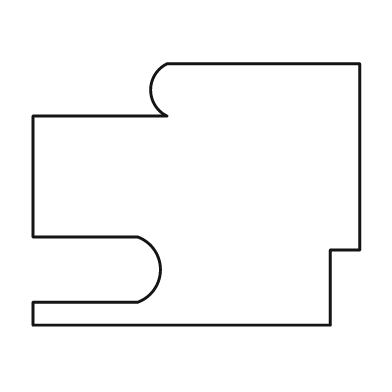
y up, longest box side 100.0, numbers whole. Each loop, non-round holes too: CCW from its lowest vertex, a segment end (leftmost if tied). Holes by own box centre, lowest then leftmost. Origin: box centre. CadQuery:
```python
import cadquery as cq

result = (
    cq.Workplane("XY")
    .moveTo(-50.0, -40.0)
    .lineTo(41.0, -40.0)
    .lineTo(41.0, -17.0)
    .lineTo(50.0, -17.0)
    .lineTo(50.0, 40.0)
    .lineTo(-9.0, 40.0)
    .threePointArc((-14.0, 32.0), (-9.0, 24.0))
    .lineTo(-50.0, 24.0)
    .lineTo(-50.0, -13.0)
    .lineTo(-18.0, -13.0)
    .threePointArc((-11.0, -23.0), (-18.0, -33.0))
    .lineTo(-50.0, -33.0)
    .close()
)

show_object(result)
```